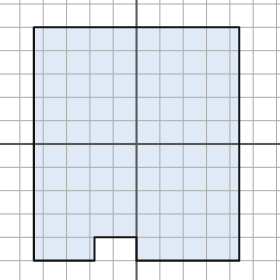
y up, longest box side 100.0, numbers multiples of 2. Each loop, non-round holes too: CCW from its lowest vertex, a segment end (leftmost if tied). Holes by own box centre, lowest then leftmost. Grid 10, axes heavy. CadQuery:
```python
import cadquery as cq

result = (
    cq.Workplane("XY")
    .moveTo(-44.0, -50.0)
    .lineTo(-18.0, -50.0)
    .lineTo(-18.0, -40.0)
    .lineTo(0.0, -40.0)
    .lineTo(0.0, -50.0)
    .lineTo(44.0, -50.0)
    .lineTo(44.0, 50.0)
    .lineTo(-44.0, 50.0)
    .close()
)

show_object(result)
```